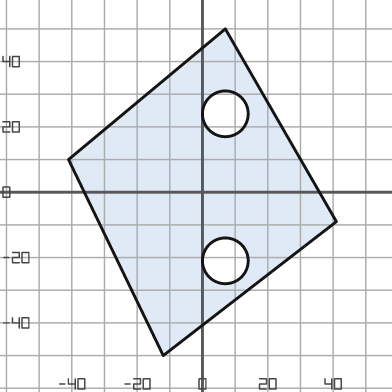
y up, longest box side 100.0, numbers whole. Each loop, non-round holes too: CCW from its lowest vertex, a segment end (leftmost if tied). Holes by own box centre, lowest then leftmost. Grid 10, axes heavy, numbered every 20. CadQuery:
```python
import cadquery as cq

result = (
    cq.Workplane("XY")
    .moveTo(-12.0, -50.0)
    .lineTo(41.0, -9.0)
    .lineTo(7.0, 50.0)
    .lineTo(-41.0, 10.0)
    .close()
    .moveTo(7.0, -21.0)
    .circle(7.0)
    .moveTo(7.0, 24.0)
    .circle(7.0)
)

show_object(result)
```